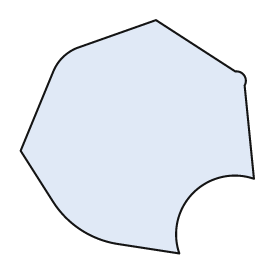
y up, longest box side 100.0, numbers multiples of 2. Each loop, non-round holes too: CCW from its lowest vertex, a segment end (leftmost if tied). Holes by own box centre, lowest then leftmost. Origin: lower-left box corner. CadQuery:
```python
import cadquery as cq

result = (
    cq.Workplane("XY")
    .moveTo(68.0, 0.0)
    .threePointArc((74.0, 26.0), (100.0, 32.0))
    .lineTo(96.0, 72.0)
    .threePointArc((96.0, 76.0), (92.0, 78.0))
    .lineTo(58.0, 100.0)
    .lineTo(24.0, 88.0)
    .threePointArc((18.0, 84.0), (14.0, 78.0))
    .lineTo(0.0, 44.0)
    .lineTo(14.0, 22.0)
    .threePointArc((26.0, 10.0), (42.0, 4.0))
    .close()
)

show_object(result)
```